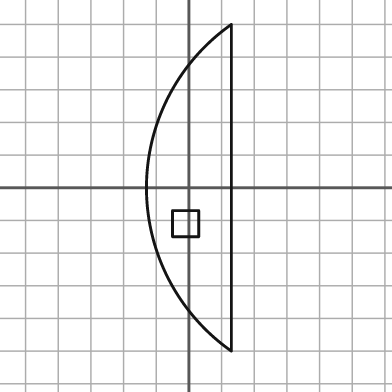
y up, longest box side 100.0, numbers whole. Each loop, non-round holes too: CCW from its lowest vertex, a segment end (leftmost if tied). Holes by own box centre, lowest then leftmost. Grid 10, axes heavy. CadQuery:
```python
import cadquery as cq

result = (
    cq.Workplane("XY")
    .moveTo(13.0, -50.0)
    .lineTo(13.0, 50.0)
    .threePointArc((-13.0, 0.0), (13.0, -50.0))
    .close()
    .moveTo(-5.0, -15.0)
    .lineTo(3.0, -15.0)
    .lineTo(3.0, -7.0)
    .lineTo(-5.0, -7.0)
    .close()
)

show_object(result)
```